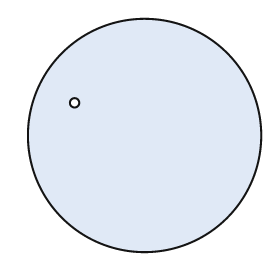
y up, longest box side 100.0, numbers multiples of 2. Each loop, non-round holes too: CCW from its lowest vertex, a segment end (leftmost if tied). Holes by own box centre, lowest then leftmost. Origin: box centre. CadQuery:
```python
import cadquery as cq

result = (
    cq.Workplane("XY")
    .moveTo(0.0, 0.0)
    .circle(50.0)
    .moveTo(-30.0, 14.0)
    .circle(2.0)
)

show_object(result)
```